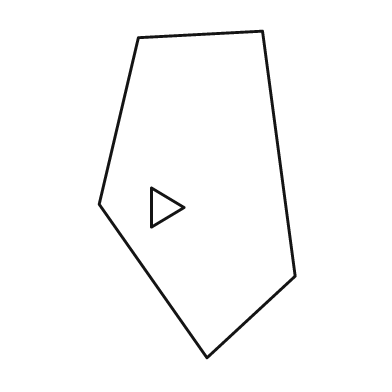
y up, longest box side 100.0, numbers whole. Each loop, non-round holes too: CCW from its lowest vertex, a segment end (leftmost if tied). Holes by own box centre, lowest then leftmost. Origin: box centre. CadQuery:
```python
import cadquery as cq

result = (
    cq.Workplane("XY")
    .moveTo(3.0, -50.0)
    .lineTo(30.0, -25.0)
    .lineTo(20.0, 50.0)
    .lineTo(-18.0, 48.0)
    .lineTo(-30.0, -3.0)
    .close()
    .moveTo(-14.0, -10.0)
    .lineTo(-4.0, -4.0)
    .lineTo(-14.0, 2.0)
    .close()
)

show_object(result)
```